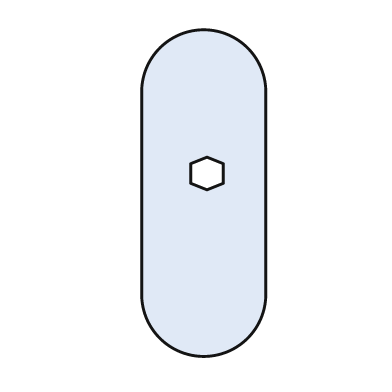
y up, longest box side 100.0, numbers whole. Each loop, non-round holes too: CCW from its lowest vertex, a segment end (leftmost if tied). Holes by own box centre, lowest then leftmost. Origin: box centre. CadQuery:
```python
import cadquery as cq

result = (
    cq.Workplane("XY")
    .moveTo(-19.0, -31.0)
    .threePointArc((0.0, -50.0), (19.0, -31.0))
    .lineTo(19.0, 31.0)
    .threePointArc((0.0, 50.0), (-19.0, 31.0))
    .close()
    .moveTo(1.0, 1.0)
    .lineTo(6.0, 3.0)
    .lineTo(6.0, 9.0)
    .lineTo(1.0, 11.0)
    .lineTo(-4.0, 9.0)
    .lineTo(-4.0, 3.0)
    .close()
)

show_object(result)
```